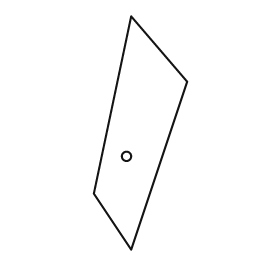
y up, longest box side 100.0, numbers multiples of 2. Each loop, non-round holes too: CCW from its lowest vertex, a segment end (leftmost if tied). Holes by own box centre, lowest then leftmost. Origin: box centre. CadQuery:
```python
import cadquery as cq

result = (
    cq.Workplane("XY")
    .moveTo(-4.0, -50.0)
    .lineTo(20.0, 22.0)
    .lineTo(-4.0, 50.0)
    .lineTo(-20.0, -26.0)
    .close()
    .moveTo(-6.0, -10.0)
    .circle(2.0)
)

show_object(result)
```